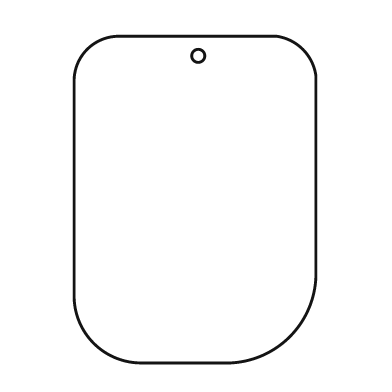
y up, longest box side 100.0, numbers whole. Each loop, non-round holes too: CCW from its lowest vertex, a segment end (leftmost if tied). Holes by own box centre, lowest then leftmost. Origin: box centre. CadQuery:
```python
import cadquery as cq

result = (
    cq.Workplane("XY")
    .moveTo(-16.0, -50.0)
    .lineTo(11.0, -50.0)
    .threePointArc((29.0, -42.0), (37.0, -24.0))
    .lineTo(37.0, 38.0)
    .threePointArc((33.0, 46.0), (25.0, 50.0))
    .lineTo(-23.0, 50.0)
    .threePointArc((-33.0, 46.0), (-37.0, 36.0))
    .lineTo(-37.0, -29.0)
    .threePointArc((-31.0, -44.0), (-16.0, -50.0))
    .close()
    .moveTo(1.0, 44.0)
    .circle(2.0)
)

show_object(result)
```